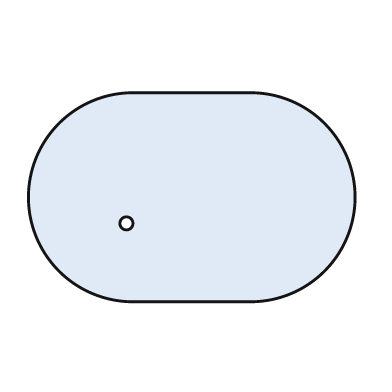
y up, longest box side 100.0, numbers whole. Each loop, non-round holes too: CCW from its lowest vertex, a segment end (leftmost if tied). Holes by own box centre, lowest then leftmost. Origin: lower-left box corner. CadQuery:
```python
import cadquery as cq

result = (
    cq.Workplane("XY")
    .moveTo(32.0, 0.0)
    .lineTo(68.0, 0.0)
    .threePointArc((100.0, 32.0), (68.0, 64.0))
    .lineTo(32.0, 64.0)
    .threePointArc((0.0, 32.0), (32.0, 0.0))
    .close()
    .moveTo(30.0, 24.0)
    .circle(2.0)
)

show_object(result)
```